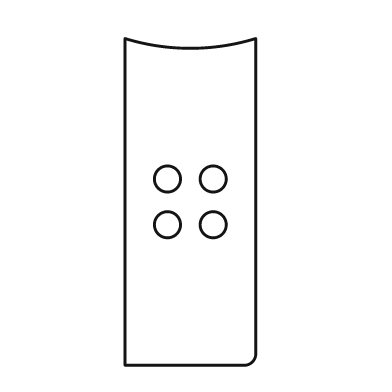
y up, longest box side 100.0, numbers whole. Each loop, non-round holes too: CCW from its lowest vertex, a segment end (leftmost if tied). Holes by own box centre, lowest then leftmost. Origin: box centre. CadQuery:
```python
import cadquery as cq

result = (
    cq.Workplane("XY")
    .moveTo(-20.0, -50.0)
    .lineTo(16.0, -50.0)
    .threePointArc((19.0, -49.0), (20.0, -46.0))
    .lineTo(20.0, 50.0)
    .threePointArc((0.0, 47.0), (-20.0, 50.0))
    .close()
    .moveTo(-7.0, -7.0)
    .circle(4.0)
    .moveTo(7.0, -7.0)
    .circle(4.0)
    .moveTo(-7.0, 7.0)
    .circle(4.0)
    .moveTo(7.0, 7.0)
    .circle(4.0)
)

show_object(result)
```